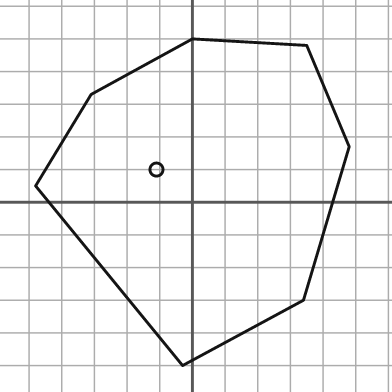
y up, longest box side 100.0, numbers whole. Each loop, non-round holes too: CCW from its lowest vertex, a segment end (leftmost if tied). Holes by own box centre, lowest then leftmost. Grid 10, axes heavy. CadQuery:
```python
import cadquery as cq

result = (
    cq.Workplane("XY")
    .moveTo(-3.0, -50.0)
    .lineTo(34.0, -30.0)
    .lineTo(48.0, 17.0)
    .lineTo(35.0, 48.0)
    .lineTo(0.0, 50.0)
    .lineTo(-31.0, 33.0)
    .lineTo(-48.0, 5.0)
    .close()
    .moveTo(-11.0, 10.0)
    .circle(2.0)
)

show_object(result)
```